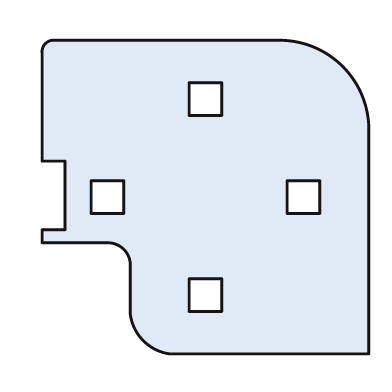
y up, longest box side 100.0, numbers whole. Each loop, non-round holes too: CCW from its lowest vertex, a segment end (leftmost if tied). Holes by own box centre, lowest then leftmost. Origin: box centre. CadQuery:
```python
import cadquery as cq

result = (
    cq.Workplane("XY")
    .moveTo(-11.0, -48.0)
    .lineTo(50.0, -48.0)
    .lineTo(50.0, 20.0)
    .threePointArc((42.0, 40.0), (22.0, 48.0))
    .lineTo(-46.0, 48.0)
    .threePointArc((-49.0, 47.0), (-50.0, 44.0))
    .lineTo(-50.0, 11.0)
    .lineTo(-43.0, 11.0)
    .lineTo(-43.0, -10.0)
    .lineTo(-50.0, -10.0)
    .lineTo(-50.0, -14.0)
    .lineTo(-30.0, -14.0)
    .threePointArc((-25.0, -16.0), (-23.0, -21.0))
    .lineTo(-23.0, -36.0)
    .threePointArc((-19.0, -44.0), (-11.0, -48.0))
    .close()
    .moveTo(-5.0, -35.0)
    .lineTo(5.0, -35.0)
    .lineTo(5.0, -25.0)
    .lineTo(-5.0, -25.0)
    .close()
    .moveTo(-35.0, -5.0)
    .lineTo(-25.0, -5.0)
    .lineTo(-25.0, 5.0)
    .lineTo(-35.0, 5.0)
    .close()
    .moveTo(25.0, -5.0)
    .lineTo(35.0, -5.0)
    .lineTo(35.0, 5.0)
    .lineTo(25.0, 5.0)
    .close()
    .moveTo(-5.0, 25.0)
    .lineTo(5.0, 25.0)
    .lineTo(5.0, 35.0)
    .lineTo(-5.0, 35.0)
    .close()
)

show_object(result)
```